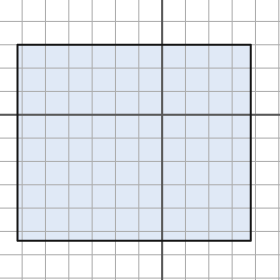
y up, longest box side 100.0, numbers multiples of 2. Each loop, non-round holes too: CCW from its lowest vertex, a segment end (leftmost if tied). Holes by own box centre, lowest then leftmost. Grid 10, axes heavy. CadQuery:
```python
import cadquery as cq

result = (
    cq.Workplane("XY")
    .moveTo(-62.0, -54.0)
    .lineTo(38.0, -54.0)
    .lineTo(38.0, 30.0)
    .lineTo(-62.0, 30.0)
    .close()
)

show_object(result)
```